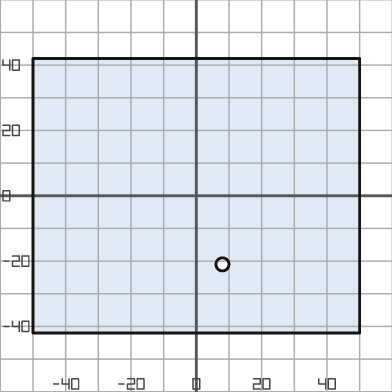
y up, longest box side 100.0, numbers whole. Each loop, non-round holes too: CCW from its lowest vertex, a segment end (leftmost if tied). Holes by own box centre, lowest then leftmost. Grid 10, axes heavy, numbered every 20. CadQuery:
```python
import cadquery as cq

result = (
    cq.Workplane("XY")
    .moveTo(-50.0, -42.0)
    .lineTo(50.0, -42.0)
    .lineTo(50.0, 42.0)
    .lineTo(-50.0, 42.0)
    .close()
    .moveTo(8.0, -21.0)
    .circle(2.0)
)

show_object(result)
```